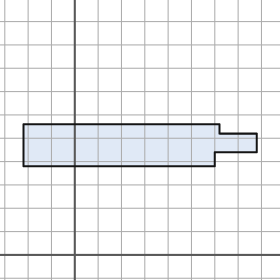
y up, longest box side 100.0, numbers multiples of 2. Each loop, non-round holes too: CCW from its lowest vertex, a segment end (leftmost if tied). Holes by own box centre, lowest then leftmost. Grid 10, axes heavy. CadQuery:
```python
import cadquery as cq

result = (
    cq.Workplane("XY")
    .moveTo(-22.0, 38.0)
    .lineTo(60.0, 38.0)
    .lineTo(60.0, 44.0)
    .lineTo(78.0, 44.0)
    .lineTo(78.0, 52.0)
    .lineTo(62.0, 52.0)
    .lineTo(62.0, 56.0)
    .lineTo(-22.0, 56.0)
    .close()
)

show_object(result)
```